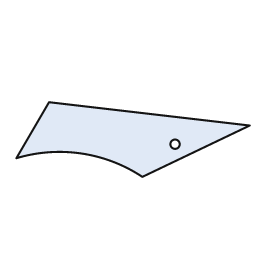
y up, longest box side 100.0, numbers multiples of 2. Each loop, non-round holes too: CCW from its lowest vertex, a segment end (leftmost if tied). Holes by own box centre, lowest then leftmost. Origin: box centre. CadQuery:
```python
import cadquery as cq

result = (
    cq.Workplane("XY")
    .moveTo(4.0, -16.0)
    .lineTo(50.0, 6.0)
    .lineTo(-36.0, 16.0)
    .lineTo(-50.0, -8.0)
    .threePointArc((-22.0, -6.0), (4.0, -16.0))
    .close()
    .moveTo(18.0, -2.0)
    .circle(2.0)
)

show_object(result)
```